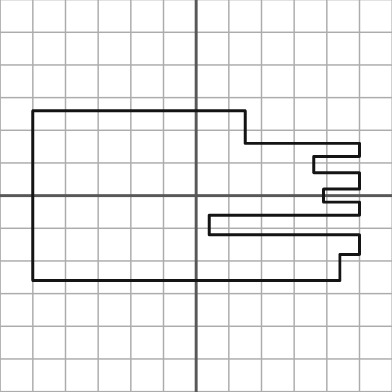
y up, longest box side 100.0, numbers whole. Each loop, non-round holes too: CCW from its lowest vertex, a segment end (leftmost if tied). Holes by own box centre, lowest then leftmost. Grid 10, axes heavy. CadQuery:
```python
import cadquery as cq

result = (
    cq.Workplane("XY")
    .moveTo(-50.0, -26.0)
    .lineTo(44.0, -26.0)
    .lineTo(44.0, -18.0)
    .lineTo(50.0, -18.0)
    .lineTo(50.0, -12.0)
    .lineTo(4.0, -12.0)
    .lineTo(4.0, -6.0)
    .lineTo(50.0, -6.0)
    .lineTo(50.0, -2.0)
    .lineTo(39.0, -2.0)
    .lineTo(39.0, 2.0)
    .lineTo(50.0, 2.0)
    .lineTo(50.0, 7.0)
    .lineTo(36.0, 7.0)
    .lineTo(36.0, 12.0)
    .lineTo(50.0, 12.0)
    .lineTo(50.0, 16.0)
    .lineTo(15.0, 16.0)
    .lineTo(15.0, 26.0)
    .lineTo(-50.0, 26.0)
    .close()
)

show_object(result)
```